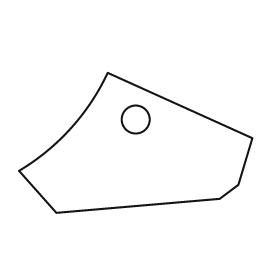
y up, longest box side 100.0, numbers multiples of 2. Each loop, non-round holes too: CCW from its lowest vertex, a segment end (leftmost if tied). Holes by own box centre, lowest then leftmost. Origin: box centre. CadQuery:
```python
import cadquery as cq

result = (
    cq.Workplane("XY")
    .moveTo(-34.0, -30.0)
    .lineTo(36.0, -24.0)
    .lineTo(44.0, -18.0)
    .lineTo(50.0, 2.0)
    .lineTo(-12.0, 30.0)
    .threePointArc((-28.0, 6.0), (-50.0, -12.0))
    .close()
    .moveTo(0.0, 10.0)
    .circle(6.0)
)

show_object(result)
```